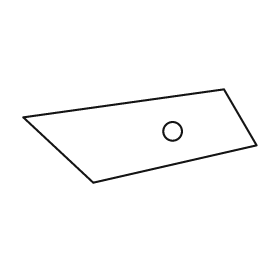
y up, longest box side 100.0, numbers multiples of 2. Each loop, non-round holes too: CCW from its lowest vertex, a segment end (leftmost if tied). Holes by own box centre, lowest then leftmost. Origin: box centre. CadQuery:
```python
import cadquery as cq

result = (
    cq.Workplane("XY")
    .moveTo(-20.0, -20.0)
    .lineTo(50.0, -4.0)
    .lineTo(36.0, 20.0)
    .lineTo(-50.0, 8.0)
    .close()
    .moveTo(14.0, 2.0)
    .circle(4.0)
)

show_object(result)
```